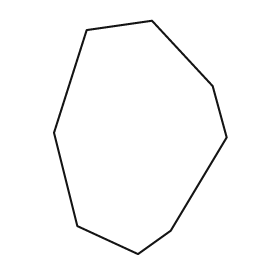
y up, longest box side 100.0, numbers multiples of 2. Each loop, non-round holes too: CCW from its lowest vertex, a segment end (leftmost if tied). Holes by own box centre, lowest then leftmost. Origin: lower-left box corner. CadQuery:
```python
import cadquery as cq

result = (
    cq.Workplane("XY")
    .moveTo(36.0, 0.0)
    .lineTo(50.0, 10.0)
    .lineTo(74.0, 50.0)
    .lineTo(68.0, 72.0)
    .lineTo(42.0, 100.0)
    .lineTo(14.0, 96.0)
    .lineTo(0.0, 52.0)
    .lineTo(10.0, 12.0)
    .close()
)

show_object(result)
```